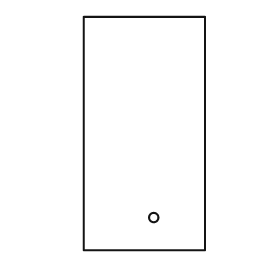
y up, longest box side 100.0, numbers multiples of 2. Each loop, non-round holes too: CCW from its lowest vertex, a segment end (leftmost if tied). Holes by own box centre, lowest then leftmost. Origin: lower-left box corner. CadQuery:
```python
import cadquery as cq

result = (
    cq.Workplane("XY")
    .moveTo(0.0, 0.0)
    .lineTo(52.0, 0.0)
    .lineTo(52.0, 100.0)
    .lineTo(0.0, 100.0)
    .close()
    .moveTo(30.0, 14.0)
    .circle(2.0)
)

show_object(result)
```